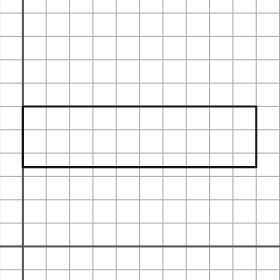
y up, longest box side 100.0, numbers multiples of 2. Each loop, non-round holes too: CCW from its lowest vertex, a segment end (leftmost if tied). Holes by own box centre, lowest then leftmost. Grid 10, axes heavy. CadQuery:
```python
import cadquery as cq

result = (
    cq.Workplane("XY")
    .moveTo(0.0, 34.0)
    .lineTo(100.0, 34.0)
    .lineTo(100.0, 60.0)
    .lineTo(0.0, 60.0)
    .close()
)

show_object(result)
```